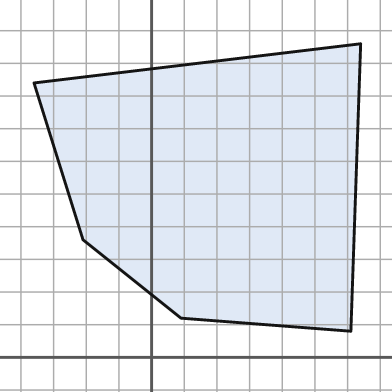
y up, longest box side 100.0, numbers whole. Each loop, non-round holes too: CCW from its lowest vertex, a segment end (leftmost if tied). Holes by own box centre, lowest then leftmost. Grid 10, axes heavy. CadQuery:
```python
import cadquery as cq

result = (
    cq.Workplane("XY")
    .moveTo(61.0, 8.0)
    .lineTo(64.0, 96.0)
    .lineTo(-36.0, 84.0)
    .lineTo(-21.0, 36.0)
    .lineTo(9.0, 12.0)
    .close()
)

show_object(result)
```